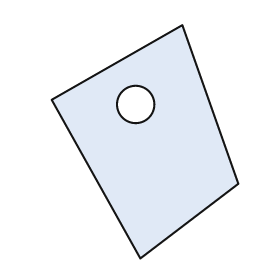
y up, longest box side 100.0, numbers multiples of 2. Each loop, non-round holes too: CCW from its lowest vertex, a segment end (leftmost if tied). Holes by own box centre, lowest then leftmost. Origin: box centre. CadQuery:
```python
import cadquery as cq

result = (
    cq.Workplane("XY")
    .moveTo(-2.0, -50.0)
    .lineTo(40.0, -18.0)
    .lineTo(16.0, 50.0)
    .lineTo(-40.0, 18.0)
    .close()
    .moveTo(-4.0, 16.0)
    .circle(8.0)
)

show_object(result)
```